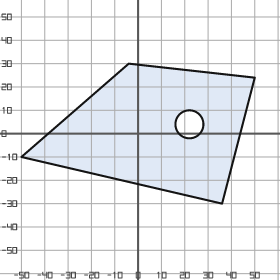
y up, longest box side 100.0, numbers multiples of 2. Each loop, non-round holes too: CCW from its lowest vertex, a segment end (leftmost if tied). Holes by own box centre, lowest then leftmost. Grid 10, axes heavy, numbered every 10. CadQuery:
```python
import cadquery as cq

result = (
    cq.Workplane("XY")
    .moveTo(36.0, -30.0)
    .lineTo(50.0, 24.0)
    .lineTo(-4.0, 30.0)
    .lineTo(-50.0, -10.0)
    .close()
    .moveTo(22.0, 4.0)
    .circle(6.0)
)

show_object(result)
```